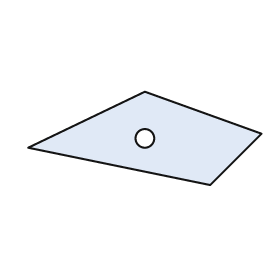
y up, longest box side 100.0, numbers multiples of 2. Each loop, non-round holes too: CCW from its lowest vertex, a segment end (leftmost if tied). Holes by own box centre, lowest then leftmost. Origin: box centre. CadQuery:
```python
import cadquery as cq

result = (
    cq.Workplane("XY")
    .moveTo(28.0, -20.0)
    .lineTo(50.0, 2.0)
    .lineTo(0.0, 20.0)
    .lineTo(-50.0, -4.0)
    .close()
    .moveTo(0.0, 0.0)
    .circle(4.0)
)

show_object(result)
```